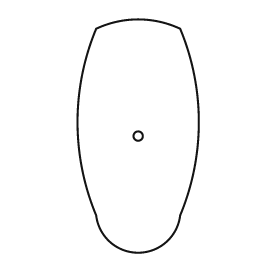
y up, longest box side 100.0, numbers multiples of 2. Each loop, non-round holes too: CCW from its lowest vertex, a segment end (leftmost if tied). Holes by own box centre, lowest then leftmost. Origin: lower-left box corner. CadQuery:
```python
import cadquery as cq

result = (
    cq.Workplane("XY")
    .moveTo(8.0, 16.0)
    .threePointArc((26.0, 0.0), (44.0, 16.0))
    .threePointArc((52.0, 56.0), (44.0, 96.0))
    .threePointArc((26.0, 100.0), (8.0, 96.0))
    .threePointArc((0.0, 56.0), (8.0, 16.0))
    .close()
    .moveTo(26.0, 50.0)
    .circle(2.0)
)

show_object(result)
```